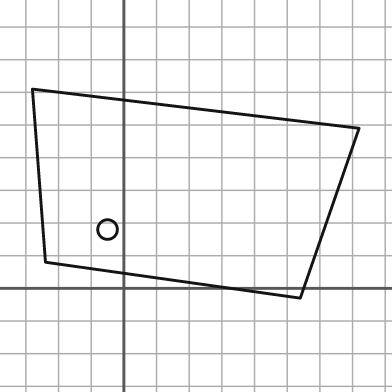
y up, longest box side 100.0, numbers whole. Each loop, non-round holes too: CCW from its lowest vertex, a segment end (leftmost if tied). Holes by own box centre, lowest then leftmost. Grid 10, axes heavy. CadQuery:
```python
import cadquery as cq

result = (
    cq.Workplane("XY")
    .moveTo(54.0, -3.0)
    .lineTo(72.0, 49.0)
    .lineTo(-28.0, 61.0)
    .lineTo(-24.0, 8.0)
    .close()
    .moveTo(-5.0, 18.0)
    .circle(3.0)
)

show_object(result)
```